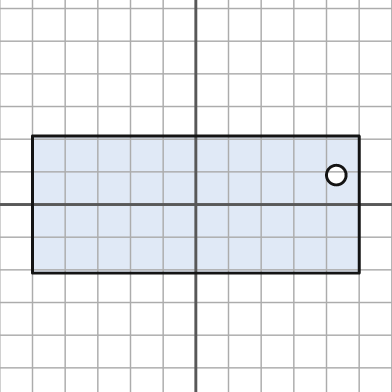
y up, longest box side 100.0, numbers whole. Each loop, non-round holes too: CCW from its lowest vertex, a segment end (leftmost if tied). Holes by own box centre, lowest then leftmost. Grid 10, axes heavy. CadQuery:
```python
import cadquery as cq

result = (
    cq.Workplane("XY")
    .moveTo(-50.0, -21.0)
    .lineTo(50.0, -21.0)
    .lineTo(50.0, 21.0)
    .lineTo(-50.0, 21.0)
    .close()
    .moveTo(43.0, 9.0)
    .circle(3.0)
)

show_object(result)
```